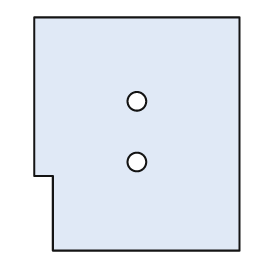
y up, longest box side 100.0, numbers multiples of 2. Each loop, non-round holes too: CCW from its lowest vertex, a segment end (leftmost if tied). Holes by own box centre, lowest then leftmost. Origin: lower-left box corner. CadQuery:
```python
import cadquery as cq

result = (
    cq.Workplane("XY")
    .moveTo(8.0, 0.0)
    .lineTo(88.0, 0.0)
    .lineTo(88.0, 100.0)
    .lineTo(0.0, 100.0)
    .lineTo(0.0, 32.0)
    .lineTo(8.0, 32.0)
    .close()
    .moveTo(44.0, 38.0)
    .circle(4.0)
    .moveTo(44.0, 64.0)
    .circle(4.0)
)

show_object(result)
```